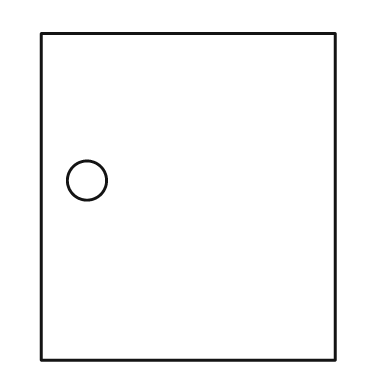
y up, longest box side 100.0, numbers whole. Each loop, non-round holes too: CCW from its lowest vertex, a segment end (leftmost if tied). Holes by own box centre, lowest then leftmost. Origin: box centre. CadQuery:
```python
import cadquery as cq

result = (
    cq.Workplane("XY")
    .moveTo(-45.0, -50.0)
    .lineTo(45.0, -50.0)
    .lineTo(45.0, 50.0)
    .lineTo(-45.0, 50.0)
    .close()
    .moveTo(-31.0, 5.0)
    .circle(6.0)
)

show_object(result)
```